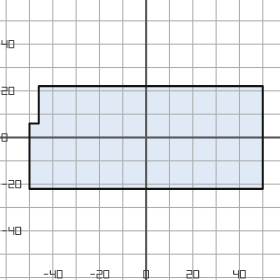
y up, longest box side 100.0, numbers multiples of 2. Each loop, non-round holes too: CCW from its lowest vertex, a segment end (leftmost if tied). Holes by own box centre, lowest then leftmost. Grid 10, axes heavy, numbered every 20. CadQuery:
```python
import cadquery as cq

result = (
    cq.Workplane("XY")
    .moveTo(-50.0, -22.0)
    .lineTo(50.0, -22.0)
    .lineTo(50.0, 22.0)
    .lineTo(-46.0, 22.0)
    .lineTo(-46.0, 6.0)
    .lineTo(-50.0, 6.0)
    .close()
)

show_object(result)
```